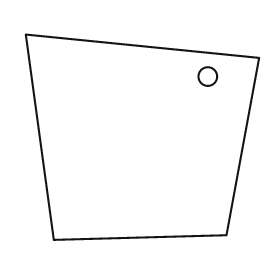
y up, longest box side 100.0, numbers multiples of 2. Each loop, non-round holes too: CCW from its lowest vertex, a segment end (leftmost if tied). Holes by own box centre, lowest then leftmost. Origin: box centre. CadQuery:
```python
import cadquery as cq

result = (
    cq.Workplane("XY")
    .moveTo(-38.0, -44.0)
    .lineTo(36.0, -42.0)
    .lineTo(50.0, 34.0)
    .lineTo(-50.0, 44.0)
    .close()
    .moveTo(28.0, 26.0)
    .circle(4.0)
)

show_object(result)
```